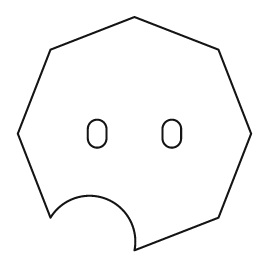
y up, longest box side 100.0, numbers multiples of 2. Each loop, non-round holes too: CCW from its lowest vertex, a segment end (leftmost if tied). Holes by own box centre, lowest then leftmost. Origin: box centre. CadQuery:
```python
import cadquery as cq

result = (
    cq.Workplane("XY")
    .moveTo(0.0, -50.0)
    .lineTo(36.0, -36.0)
    .lineTo(50.0, 0.0)
    .lineTo(36.0, 36.0)
    .lineTo(0.0, 50.0)
    .lineTo(-36.0, 36.0)
    .lineTo(-50.0, 0.0)
    .lineTo(-36.0, -36.0)
    .threePointArc((-12.0, -28.0), (0.0, -50.0))
    .close()
    .moveTo(-20.0, -2.0)
    .threePointArc((-16.0, -6.0), (-12.0, -2.0))
    .lineTo(-12.0, 2.0)
    .threePointArc((-16.0, 6.0), (-20.0, 2.0))
    .close()
    .moveTo(12.0, -2.0)
    .threePointArc((16.0, -6.0), (20.0, -2.0))
    .lineTo(20.0, 2.0)
    .threePointArc((16.0, 6.0), (12.0, 2.0))
    .close()
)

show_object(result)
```